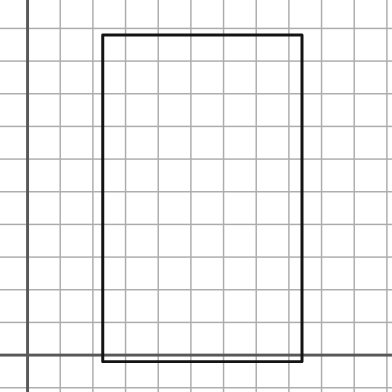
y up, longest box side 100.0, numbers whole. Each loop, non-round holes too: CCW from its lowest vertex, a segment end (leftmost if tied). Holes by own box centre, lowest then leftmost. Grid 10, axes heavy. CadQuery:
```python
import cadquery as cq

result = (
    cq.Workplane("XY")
    .moveTo(23.0, -2.0)
    .lineTo(84.0, -2.0)
    .lineTo(84.0, 98.0)
    .lineTo(23.0, 98.0)
    .close()
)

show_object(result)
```